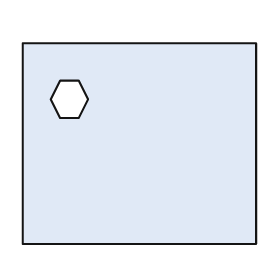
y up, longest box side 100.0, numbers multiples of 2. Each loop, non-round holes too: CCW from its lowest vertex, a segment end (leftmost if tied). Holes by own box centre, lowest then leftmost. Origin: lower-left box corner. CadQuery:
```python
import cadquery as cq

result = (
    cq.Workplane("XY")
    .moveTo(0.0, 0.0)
    .lineTo(100.0, 0.0)
    .lineTo(100.0, 86.0)
    .lineTo(0.0, 86.0)
    .close()
    .moveTo(16.0, 54.0)
    .lineTo(24.0, 54.0)
    .lineTo(28.0, 62.0)
    .lineTo(24.0, 70.0)
    .lineTo(16.0, 70.0)
    .lineTo(12.0, 62.0)
    .close()
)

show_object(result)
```